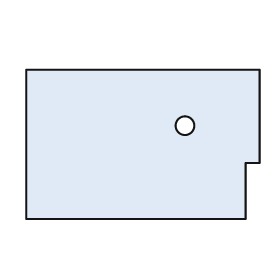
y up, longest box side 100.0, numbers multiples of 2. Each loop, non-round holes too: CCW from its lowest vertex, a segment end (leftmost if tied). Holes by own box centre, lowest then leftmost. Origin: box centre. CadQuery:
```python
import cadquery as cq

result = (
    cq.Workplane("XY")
    .moveTo(-50.0, -32.0)
    .lineTo(44.0, -32.0)
    .lineTo(44.0, -8.0)
    .lineTo(50.0, -8.0)
    .lineTo(50.0, 32.0)
    .lineTo(-50.0, 32.0)
    .close()
    .moveTo(18.0, 8.0)
    .circle(4.0)
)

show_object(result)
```